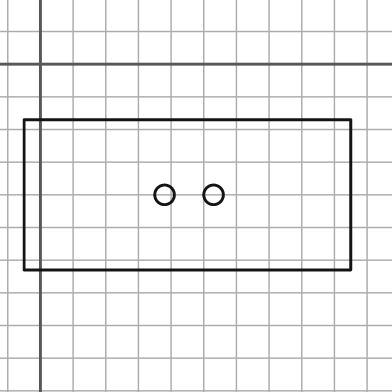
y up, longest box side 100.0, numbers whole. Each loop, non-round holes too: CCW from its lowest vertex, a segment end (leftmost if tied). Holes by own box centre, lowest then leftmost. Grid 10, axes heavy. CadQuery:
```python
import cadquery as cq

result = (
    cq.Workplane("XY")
    .moveTo(-5.0, -63.0)
    .lineTo(95.0, -63.0)
    .lineTo(95.0, -17.0)
    .lineTo(-5.0, -17.0)
    .close()
    .moveTo(38.0, -40.0)
    .circle(3.0)
    .moveTo(53.0, -40.0)
    .circle(3.0)
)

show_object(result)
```